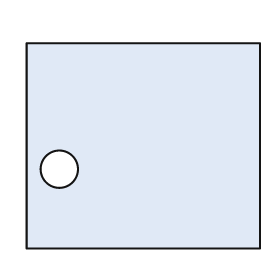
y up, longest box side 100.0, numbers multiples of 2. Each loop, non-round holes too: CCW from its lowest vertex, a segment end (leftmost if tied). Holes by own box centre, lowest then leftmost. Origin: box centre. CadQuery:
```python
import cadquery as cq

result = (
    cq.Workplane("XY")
    .moveTo(-50.0, -44.0)
    .lineTo(50.0, -44.0)
    .lineTo(50.0, 44.0)
    .lineTo(-50.0, 44.0)
    .close()
    .moveTo(-36.0, -10.0)
    .circle(8.0)
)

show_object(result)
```